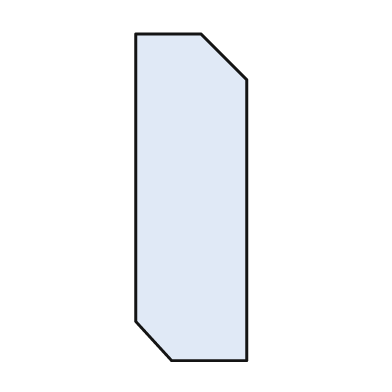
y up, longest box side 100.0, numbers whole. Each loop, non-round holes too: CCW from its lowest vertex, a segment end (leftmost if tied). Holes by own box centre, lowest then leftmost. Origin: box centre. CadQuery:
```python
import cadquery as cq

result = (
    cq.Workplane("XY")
    .moveTo(-6.0, -50.0)
    .lineTo(17.0, -50.0)
    .lineTo(17.0, 36.0)
    .lineTo(3.0, 50.0)
    .lineTo(-17.0, 50.0)
    .lineTo(-17.0, -38.0)
    .close()
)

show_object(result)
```